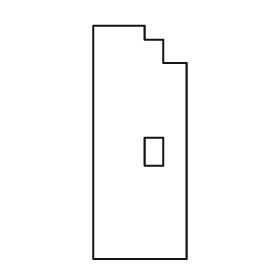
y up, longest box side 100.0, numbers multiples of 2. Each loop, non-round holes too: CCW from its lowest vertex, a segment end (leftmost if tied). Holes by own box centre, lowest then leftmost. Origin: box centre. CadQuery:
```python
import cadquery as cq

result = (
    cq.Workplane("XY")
    .moveTo(-20.0, -50.0)
    .lineTo(20.0, -50.0)
    .lineTo(20.0, 34.0)
    .lineTo(10.0, 34.0)
    .lineTo(10.0, 44.0)
    .lineTo(2.0, 44.0)
    .lineTo(2.0, 50.0)
    .lineTo(-20.0, 50.0)
    .close()
    .moveTo(2.0, -10.0)
    .lineTo(10.0, -10.0)
    .lineTo(10.0, 2.0)
    .lineTo(2.0, 2.0)
    .close()
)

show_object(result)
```